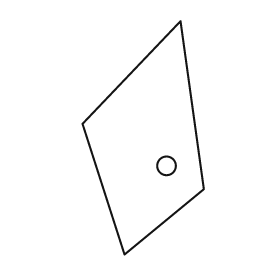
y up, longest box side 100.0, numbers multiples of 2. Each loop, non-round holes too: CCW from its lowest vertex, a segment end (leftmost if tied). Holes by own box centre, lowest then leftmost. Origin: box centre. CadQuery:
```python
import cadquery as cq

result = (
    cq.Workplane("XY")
    .moveTo(-8.0, -50.0)
    .lineTo(26.0, -22.0)
    .lineTo(16.0, 50.0)
    .lineTo(-26.0, 6.0)
    .close()
    .moveTo(10.0, -12.0)
    .circle(4.0)
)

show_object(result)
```